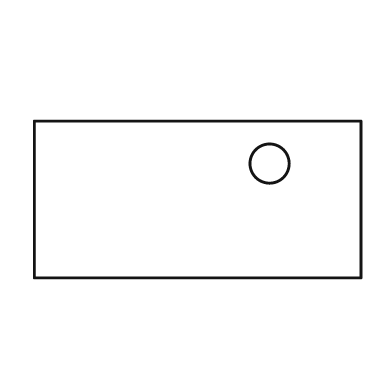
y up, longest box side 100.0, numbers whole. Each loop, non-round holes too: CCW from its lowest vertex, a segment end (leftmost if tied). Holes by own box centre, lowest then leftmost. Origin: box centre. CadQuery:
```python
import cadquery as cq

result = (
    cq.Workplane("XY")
    .moveTo(-50.0, -24.0)
    .lineTo(50.0, -24.0)
    .lineTo(50.0, 24.0)
    .lineTo(-50.0, 24.0)
    .close()
    .moveTo(22.0, 11.0)
    .circle(6.0)
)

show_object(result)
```